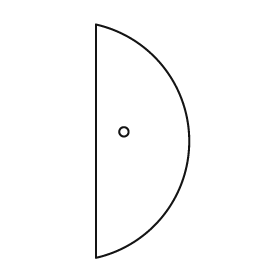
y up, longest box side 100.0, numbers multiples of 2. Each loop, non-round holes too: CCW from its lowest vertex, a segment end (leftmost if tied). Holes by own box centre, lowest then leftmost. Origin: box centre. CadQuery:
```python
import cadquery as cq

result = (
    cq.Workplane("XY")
    .moveTo(-20.0, -50.0)
    .threePointArc((20.0, 0.0), (-20.0, 50.0))
    .close()
    .moveTo(-8.0, 4.0)
    .circle(2.0)
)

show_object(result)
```